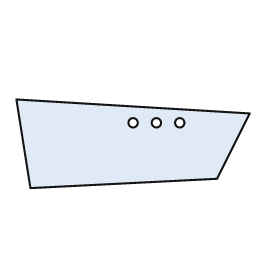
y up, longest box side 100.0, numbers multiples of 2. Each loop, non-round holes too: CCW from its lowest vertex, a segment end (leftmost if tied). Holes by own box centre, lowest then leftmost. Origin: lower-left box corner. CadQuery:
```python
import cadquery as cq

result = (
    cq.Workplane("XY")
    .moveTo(6.0, 0.0)
    .lineTo(86.0, 4.0)
    .lineTo(100.0, 32.0)
    .lineTo(0.0, 38.0)
    .close()
    .moveTo(50.0, 28.0)
    .circle(2.0)
    .moveTo(60.0, 28.0)
    .circle(2.0)
    .moveTo(70.0, 28.0)
    .circle(2.0)
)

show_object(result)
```